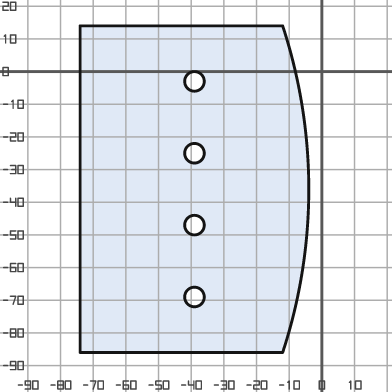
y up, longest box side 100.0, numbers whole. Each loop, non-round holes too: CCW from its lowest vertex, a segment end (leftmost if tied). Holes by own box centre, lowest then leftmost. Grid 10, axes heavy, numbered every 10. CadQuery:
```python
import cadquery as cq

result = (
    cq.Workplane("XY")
    .moveTo(-74.0, -86.0)
    .lineTo(-12.0, -86.0)
    .threePointArc((-4.0, -36.0), (-12.0, 14.0))
    .lineTo(-74.0, 14.0)
    .close()
    .moveTo(-39.0, -69.0)
    .circle(3.0)
    .moveTo(-39.0, -47.0)
    .circle(3.0)
    .moveTo(-39.0, -25.0)
    .circle(3.0)
    .moveTo(-39.0, -3.0)
    .circle(3.0)
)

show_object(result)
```